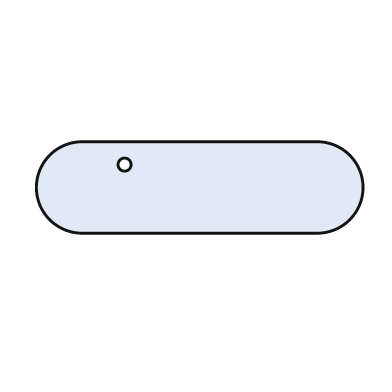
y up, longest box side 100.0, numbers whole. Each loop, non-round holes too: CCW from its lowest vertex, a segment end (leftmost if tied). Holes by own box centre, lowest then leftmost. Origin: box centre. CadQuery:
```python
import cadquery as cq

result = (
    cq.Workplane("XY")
    .moveTo(-36.0, -14.0)
    .lineTo(36.0, -14.0)
    .threePointArc((50.0, 0.0), (36.0, 14.0))
    .lineTo(-36.0, 14.0)
    .threePointArc((-50.0, 0.0), (-36.0, -14.0))
    .close()
    .moveTo(-23.0, 7.0)
    .circle(2.0)
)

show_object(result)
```